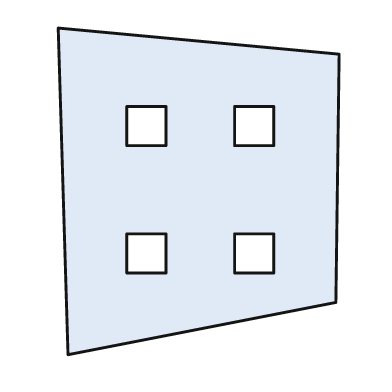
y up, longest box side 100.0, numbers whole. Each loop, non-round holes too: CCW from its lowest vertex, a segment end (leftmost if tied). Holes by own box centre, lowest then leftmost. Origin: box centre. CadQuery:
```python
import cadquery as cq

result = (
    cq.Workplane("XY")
    .moveTo(-40.0, -50.0)
    .lineTo(42.0, -34.0)
    .lineTo(43.0, 42.0)
    .lineTo(-43.0, 50.0)
    .close()
    .moveTo(-22.0, -25.0)
    .lineTo(-10.0, -25.0)
    .lineTo(-10.0, -13.0)
    .lineTo(-22.0, -13.0)
    .close()
    .moveTo(11.0, -25.0)
    .lineTo(23.0, -25.0)
    .lineTo(23.0, -13.0)
    .lineTo(11.0, -13.0)
    .close()
    .moveTo(-22.0, 14.0)
    .lineTo(-10.0, 14.0)
    .lineTo(-10.0, 26.0)
    .lineTo(-22.0, 26.0)
    .close()
    .moveTo(11.0, 14.0)
    .lineTo(23.0, 14.0)
    .lineTo(23.0, 26.0)
    .lineTo(11.0, 26.0)
    .close()
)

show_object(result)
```